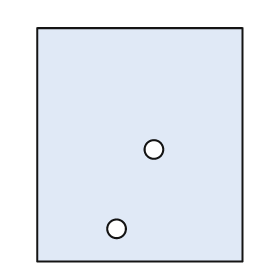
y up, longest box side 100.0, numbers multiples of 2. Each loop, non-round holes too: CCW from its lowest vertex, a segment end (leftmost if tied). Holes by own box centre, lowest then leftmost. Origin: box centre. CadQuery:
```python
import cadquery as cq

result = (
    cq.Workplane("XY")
    .moveTo(-44.0, -50.0)
    .lineTo(44.0, -50.0)
    .lineTo(44.0, 50.0)
    .lineTo(-44.0, 50.0)
    .close()
    .moveTo(-10.0, -36.0)
    .circle(4.0)
    .moveTo(6.0, -2.0)
    .circle(4.0)
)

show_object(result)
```